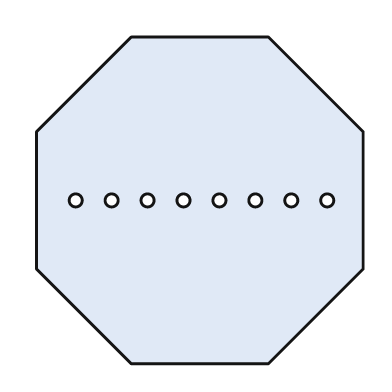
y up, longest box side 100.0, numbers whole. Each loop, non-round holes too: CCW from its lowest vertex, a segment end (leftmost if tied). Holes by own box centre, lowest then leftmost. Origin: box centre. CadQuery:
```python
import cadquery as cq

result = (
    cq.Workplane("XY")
    .moveTo(-21.0, -50.0)
    .lineTo(21.0, -50.0)
    .lineTo(50.0, -21.0)
    .lineTo(50.0, 21.0)
    .lineTo(21.0, 50.0)
    .lineTo(-21.0, 50.0)
    .lineTo(-50.0, 21.0)
    .lineTo(-50.0, -21.0)
    .close()
    .moveTo(-38.0, 0.0)
    .circle(2.0)
    .moveTo(-27.0, 0.0)
    .circle(2.0)
    .moveTo(-16.0, 0.0)
    .circle(2.0)
    .moveTo(-5.0, 0.0)
    .circle(2.0)
    .moveTo(6.0, 0.0)
    .circle(2.0)
    .moveTo(17.0, 0.0)
    .circle(2.0)
    .moveTo(28.0, 0.0)
    .circle(2.0)
    .moveTo(39.0, 0.0)
    .circle(2.0)
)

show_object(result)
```